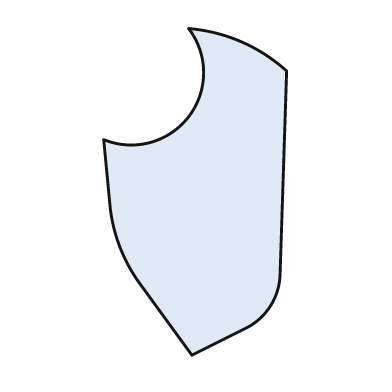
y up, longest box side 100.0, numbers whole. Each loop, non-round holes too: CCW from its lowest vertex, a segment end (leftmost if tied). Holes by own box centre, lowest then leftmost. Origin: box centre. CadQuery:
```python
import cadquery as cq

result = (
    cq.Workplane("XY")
    .moveTo(-1.0, -50.0)
    .lineTo(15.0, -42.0)
    .threePointArc((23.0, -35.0), (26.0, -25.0))
    .lineTo(28.0, 37.0)
    .threePointArc((14.0, 46.0), (-2.0, 50.0))
    .threePointArc((-2.0, 23.0), (-28.0, 16.0))
    .lineTo(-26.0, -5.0)
    .threePointArc((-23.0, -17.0), (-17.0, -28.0))
    .close()
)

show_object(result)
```